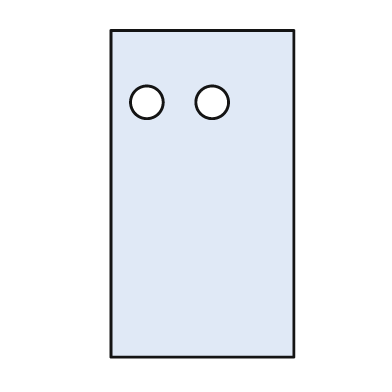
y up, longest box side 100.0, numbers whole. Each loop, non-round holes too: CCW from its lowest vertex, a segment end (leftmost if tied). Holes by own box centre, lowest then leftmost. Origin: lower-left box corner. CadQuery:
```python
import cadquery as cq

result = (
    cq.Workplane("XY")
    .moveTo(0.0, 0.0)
    .lineTo(56.0, 0.0)
    .lineTo(56.0, 100.0)
    .lineTo(0.0, 100.0)
    .close()
    .moveTo(11.0, 78.0)
    .circle(5.0)
    .moveTo(31.0, 78.0)
    .circle(5.0)
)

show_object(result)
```